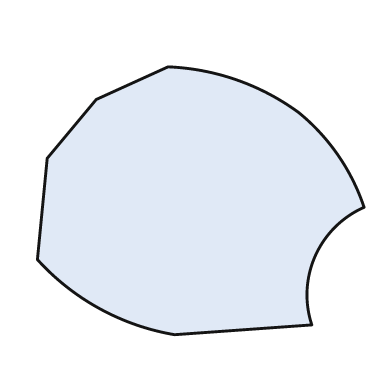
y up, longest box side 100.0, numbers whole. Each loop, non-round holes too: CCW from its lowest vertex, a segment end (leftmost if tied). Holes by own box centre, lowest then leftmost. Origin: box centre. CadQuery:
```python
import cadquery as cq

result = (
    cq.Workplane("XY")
    .moveTo(-8.0, -41.0)
    .lineTo(34.0, -38.0)
    .threePointArc((35.0, -17.0), (50.0, -2.0))
    .threePointArc((42.0, 14.0), (30.0, 27.0))
    .threePointArc((11.0, 37.0), (-10.0, 41.0))
    .lineTo(-32.0, 31.0)
    .lineTo(-47.0, 13.0)
    .lineTo(-50.0, -18.0)
    .threePointArc((-31.0, -33.0), (-8.0, -41.0))
    .close()
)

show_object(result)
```